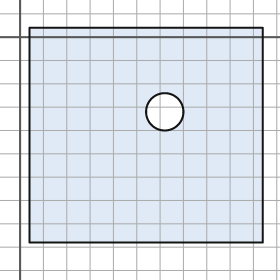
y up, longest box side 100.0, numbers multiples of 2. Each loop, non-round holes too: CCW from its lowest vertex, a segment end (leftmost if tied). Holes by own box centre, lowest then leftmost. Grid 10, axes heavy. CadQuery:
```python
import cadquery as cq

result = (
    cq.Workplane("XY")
    .moveTo(4.0, -88.0)
    .lineTo(104.0, -88.0)
    .lineTo(104.0, 4.0)
    .lineTo(4.0, 4.0)
    .close()
    .moveTo(62.0, -32.0)
    .circle(8.0)
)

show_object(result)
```